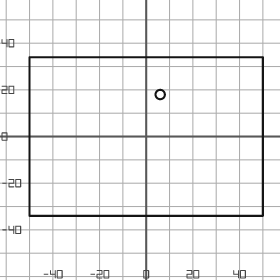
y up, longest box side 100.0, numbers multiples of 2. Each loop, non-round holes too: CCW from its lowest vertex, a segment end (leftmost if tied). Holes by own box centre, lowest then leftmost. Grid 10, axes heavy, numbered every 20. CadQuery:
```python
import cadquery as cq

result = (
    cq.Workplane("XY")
    .moveTo(-50.0, -34.0)
    .lineTo(50.0, -34.0)
    .lineTo(50.0, 34.0)
    .lineTo(-50.0, 34.0)
    .close()
    .moveTo(6.0, 18.0)
    .circle(2.0)
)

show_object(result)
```